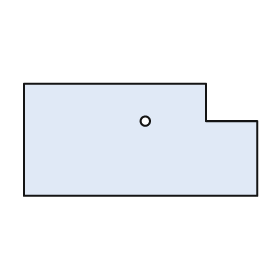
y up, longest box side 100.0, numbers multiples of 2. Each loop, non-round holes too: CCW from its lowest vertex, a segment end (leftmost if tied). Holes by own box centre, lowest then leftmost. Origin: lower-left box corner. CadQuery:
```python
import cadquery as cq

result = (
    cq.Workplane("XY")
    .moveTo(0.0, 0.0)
    .lineTo(100.0, 0.0)
    .lineTo(100.0, 32.0)
    .lineTo(78.0, 32.0)
    .lineTo(78.0, 48.0)
    .lineTo(0.0, 48.0)
    .close()
    .moveTo(52.0, 32.0)
    .circle(2.0)
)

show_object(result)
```